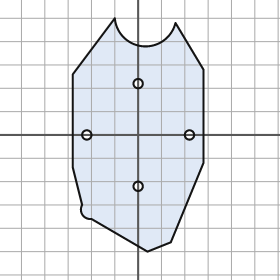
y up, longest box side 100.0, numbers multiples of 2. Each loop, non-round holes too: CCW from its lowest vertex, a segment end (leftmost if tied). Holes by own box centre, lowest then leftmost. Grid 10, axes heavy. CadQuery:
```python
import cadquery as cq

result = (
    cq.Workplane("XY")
    .moveTo(4.0, -50.0)
    .lineTo(14.0, -46.0)
    .lineTo(28.0, -12.0)
    .lineTo(28.0, 28.0)
    .lineTo(16.0, 48.0)
    .threePointArc((2.0, 38.0), (-10.0, 50.0))
    .lineTo(-28.0, 26.0)
    .lineTo(-28.0, -14.0)
    .lineTo(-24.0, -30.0)
    .threePointArc((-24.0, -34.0), (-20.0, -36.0))
    .close()
    .moveTo(0.0, -22.0)
    .circle(2.0)
    .moveTo(-22.0, 0.0)
    .circle(2.0)
    .moveTo(22.0, 0.0)
    .circle(2.0)
    .moveTo(0.0, 22.0)
    .circle(2.0)
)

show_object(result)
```